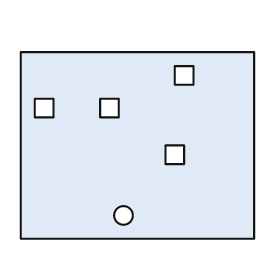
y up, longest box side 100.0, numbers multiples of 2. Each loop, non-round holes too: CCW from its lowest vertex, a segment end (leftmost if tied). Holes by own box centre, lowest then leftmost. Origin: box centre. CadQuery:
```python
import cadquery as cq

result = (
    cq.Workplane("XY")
    .moveTo(-50.0, -40.0)
    .lineTo(50.0, -40.0)
    .lineTo(50.0, 40.0)
    .lineTo(-50.0, 40.0)
    .close()
    .moveTo(-6.0, -30.0)
    .circle(4.0)
    .moveTo(12.0, -8.0)
    .lineTo(20.0, -8.0)
    .lineTo(20.0, 0.0)
    .lineTo(12.0, 0.0)
    .close()
    .moveTo(-44.0, 12.0)
    .lineTo(-36.0, 12.0)
    .lineTo(-36.0, 20.0)
    .lineTo(-44.0, 20.0)
    .close()
    .moveTo(-16.0, 12.0)
    .lineTo(-8.0, 12.0)
    .lineTo(-8.0, 20.0)
    .lineTo(-16.0, 20.0)
    .close()
    .moveTo(16.0, 26.0)
    .lineTo(24.0, 26.0)
    .lineTo(24.0, 34.0)
    .lineTo(16.0, 34.0)
    .close()
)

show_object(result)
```